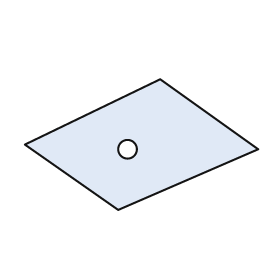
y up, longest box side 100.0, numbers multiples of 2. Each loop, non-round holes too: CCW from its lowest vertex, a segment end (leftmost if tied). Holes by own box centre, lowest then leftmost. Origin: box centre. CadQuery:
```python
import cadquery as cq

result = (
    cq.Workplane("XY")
    .moveTo(-10.0, -28.0)
    .lineTo(50.0, -2.0)
    .lineTo(8.0, 28.0)
    .lineTo(-50.0, 0.0)
    .close()
    .moveTo(-6.0, -2.0)
    .circle(4.0)
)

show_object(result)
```